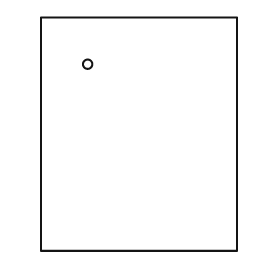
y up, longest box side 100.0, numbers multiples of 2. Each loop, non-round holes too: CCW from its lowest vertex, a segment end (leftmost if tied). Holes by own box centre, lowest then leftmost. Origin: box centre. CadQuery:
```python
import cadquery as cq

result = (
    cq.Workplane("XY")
    .moveTo(-42.0, -50.0)
    .lineTo(42.0, -50.0)
    .lineTo(42.0, 50.0)
    .lineTo(-42.0, 50.0)
    .close()
    .moveTo(-22.0, 30.0)
    .circle(2.0)
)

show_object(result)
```